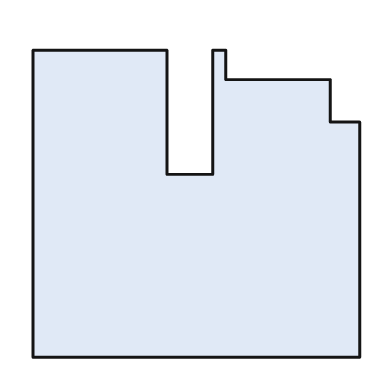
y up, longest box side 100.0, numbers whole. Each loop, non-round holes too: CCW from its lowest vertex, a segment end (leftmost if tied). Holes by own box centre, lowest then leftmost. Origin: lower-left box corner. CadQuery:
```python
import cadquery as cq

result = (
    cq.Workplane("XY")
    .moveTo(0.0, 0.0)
    .lineTo(100.0, 0.0)
    .lineTo(100.0, 72.0)
    .lineTo(91.0, 72.0)
    .lineTo(91.0, 85.0)
    .lineTo(59.0, 85.0)
    .lineTo(59.0, 94.0)
    .lineTo(55.0, 94.0)
    .lineTo(55.0, 56.0)
    .lineTo(41.0, 56.0)
    .lineTo(41.0, 94.0)
    .lineTo(0.0, 94.0)
    .close()
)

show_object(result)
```